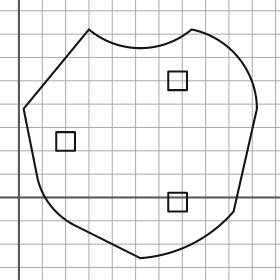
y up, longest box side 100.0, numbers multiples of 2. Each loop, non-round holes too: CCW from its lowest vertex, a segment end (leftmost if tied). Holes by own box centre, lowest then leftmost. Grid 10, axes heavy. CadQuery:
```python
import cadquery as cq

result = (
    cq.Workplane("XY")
    .moveTo(52.0, -26.0)
    .threePointArc((74.0, -20.0), (92.0, -6.0))
    .lineTo(102.0, 38.0)
    .threePointArc((94.0, 60.0), (74.0, 72.0))
    .threePointArc((52.0, 64.0), (30.0, 72.0))
    .lineTo(2.0, 38.0)
    .lineTo(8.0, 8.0)
    .threePointArc((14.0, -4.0), (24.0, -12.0))
    .close()
    .moveTo(64.0, -6.0)
    .lineTo(72.0, -6.0)
    .lineTo(72.0, 2.0)
    .lineTo(64.0, 2.0)
    .close()
    .moveTo(16.0, 20.0)
    .lineTo(24.0, 20.0)
    .lineTo(24.0, 28.0)
    .lineTo(16.0, 28.0)
    .close()
    .moveTo(64.0, 46.0)
    .lineTo(72.0, 46.0)
    .lineTo(72.0, 54.0)
    .lineTo(64.0, 54.0)
    .close()
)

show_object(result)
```